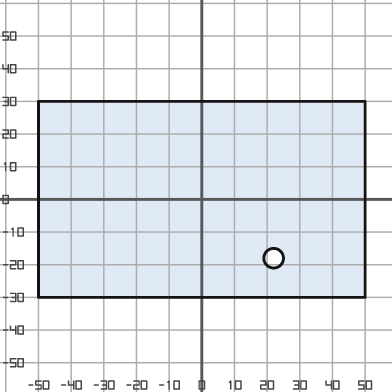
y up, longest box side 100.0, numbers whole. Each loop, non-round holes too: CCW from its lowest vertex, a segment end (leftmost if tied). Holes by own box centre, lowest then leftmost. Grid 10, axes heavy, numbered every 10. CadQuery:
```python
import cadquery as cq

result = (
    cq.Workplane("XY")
    .moveTo(-50.0, -30.0)
    .lineTo(50.0, -30.0)
    .lineTo(50.0, 30.0)
    .lineTo(-50.0, 30.0)
    .close()
    .moveTo(22.0, -18.0)
    .circle(3.0)
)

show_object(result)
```